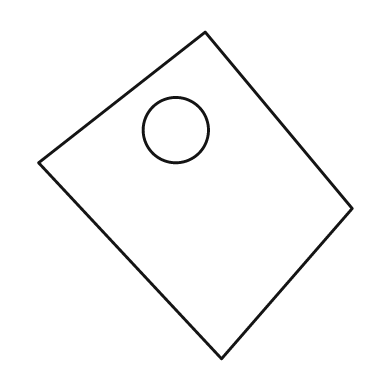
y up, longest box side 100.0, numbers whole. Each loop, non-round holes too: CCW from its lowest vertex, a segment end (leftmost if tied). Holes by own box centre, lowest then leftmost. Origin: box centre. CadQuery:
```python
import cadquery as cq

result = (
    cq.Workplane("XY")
    .moveTo(8.0, -50.0)
    .lineTo(48.0, -4.0)
    .lineTo(3.0, 50.0)
    .lineTo(-48.0, 10.0)
    .close()
    .moveTo(-6.0, 20.0)
    .circle(10.0)
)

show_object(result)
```